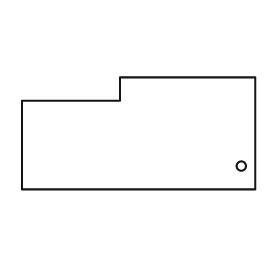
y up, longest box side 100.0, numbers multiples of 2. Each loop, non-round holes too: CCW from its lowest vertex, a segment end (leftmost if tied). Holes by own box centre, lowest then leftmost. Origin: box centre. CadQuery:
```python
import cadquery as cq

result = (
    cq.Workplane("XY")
    .moveTo(-50.0, -24.0)
    .lineTo(50.0, -24.0)
    .lineTo(50.0, 24.0)
    .lineTo(-8.0, 24.0)
    .lineTo(-8.0, 14.0)
    .lineTo(-50.0, 14.0)
    .close()
    .moveTo(44.0, -14.0)
    .circle(2.0)
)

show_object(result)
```